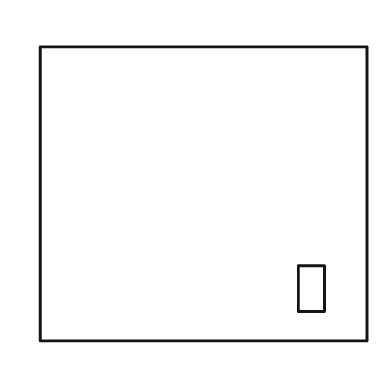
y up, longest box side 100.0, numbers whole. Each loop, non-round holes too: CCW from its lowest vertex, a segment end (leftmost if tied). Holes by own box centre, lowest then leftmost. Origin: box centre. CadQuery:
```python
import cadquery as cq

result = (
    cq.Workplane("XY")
    .moveTo(-50.0, -45.0)
    .lineTo(50.0, -45.0)
    .lineTo(50.0, 45.0)
    .lineTo(-50.0, 45.0)
    .close()
    .moveTo(29.0, -36.0)
    .lineTo(37.0, -36.0)
    .lineTo(37.0, -22.0)
    .lineTo(29.0, -22.0)
    .close()
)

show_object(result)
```